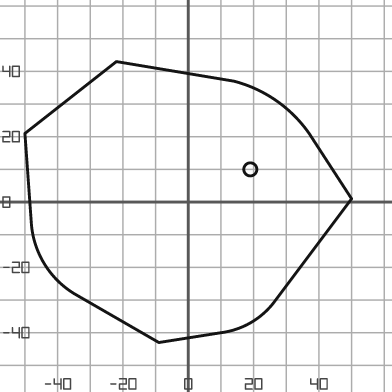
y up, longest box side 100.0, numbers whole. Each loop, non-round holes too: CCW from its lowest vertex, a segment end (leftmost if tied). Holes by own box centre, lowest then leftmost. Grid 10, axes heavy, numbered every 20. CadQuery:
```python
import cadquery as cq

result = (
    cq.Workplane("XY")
    .moveTo(-9.0, -43.0)
    .lineTo(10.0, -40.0)
    .threePointArc((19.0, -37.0), (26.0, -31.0))
    .lineTo(50.0, 1.0)
    .lineTo(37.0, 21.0)
    .threePointArc((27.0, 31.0), (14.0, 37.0))
    .lineTo(-22.0, 43.0)
    .lineTo(-50.0, 21.0)
    .lineTo(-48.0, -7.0)
    .threePointArc((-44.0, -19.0), (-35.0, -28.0))
    .close()
    .moveTo(19.0, 10.0)
    .circle(2.0)
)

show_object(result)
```